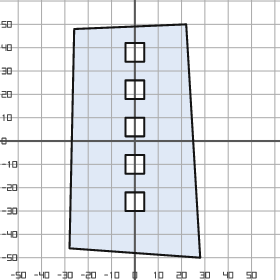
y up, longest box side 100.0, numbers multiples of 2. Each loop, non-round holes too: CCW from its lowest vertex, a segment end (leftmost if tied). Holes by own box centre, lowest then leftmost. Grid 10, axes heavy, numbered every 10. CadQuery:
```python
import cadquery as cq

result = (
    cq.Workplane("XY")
    .moveTo(28.0, -50.0)
    .lineTo(22.0, 50.0)
    .lineTo(-26.0, 48.0)
    .lineTo(-28.0, -46.0)
    .close()
    .moveTo(-4.0, -30.0)
    .lineTo(4.0, -30.0)
    .lineTo(4.0, -22.0)
    .lineTo(-4.0, -22.0)
    .close()
    .moveTo(-4.0, -14.0)
    .lineTo(4.0, -14.0)
    .lineTo(4.0, -6.0)
    .lineTo(-4.0, -6.0)
    .close()
    .moveTo(-4.0, 2.0)
    .lineTo(4.0, 2.0)
    .lineTo(4.0, 10.0)
    .lineTo(-4.0, 10.0)
    .close()
    .moveTo(-4.0, 18.0)
    .lineTo(4.0, 18.0)
    .lineTo(4.0, 26.0)
    .lineTo(-4.0, 26.0)
    .close()
    .moveTo(-4.0, 34.0)
    .lineTo(4.0, 34.0)
    .lineTo(4.0, 42.0)
    .lineTo(-4.0, 42.0)
    .close()
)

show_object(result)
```